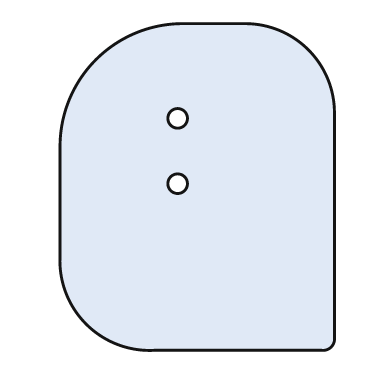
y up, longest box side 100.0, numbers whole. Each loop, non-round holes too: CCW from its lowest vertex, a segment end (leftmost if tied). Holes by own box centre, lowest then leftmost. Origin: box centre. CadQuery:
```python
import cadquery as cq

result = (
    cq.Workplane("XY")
    .moveTo(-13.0, -50.0)
    .lineTo(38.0, -50.0)
    .threePointArc((41.0, -49.0), (42.0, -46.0))
    .lineTo(42.0, 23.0)
    .threePointArc((34.0, 42.0), (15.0, 50.0))
    .lineTo(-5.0, 50.0)
    .threePointArc((-31.0, 39.0), (-42.0, 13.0))
    .lineTo(-42.0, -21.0)
    .threePointArc((-34.0, -42.0), (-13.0, -50.0))
    .close()
    .moveTo(-6.0, 1.0)
    .circle(3.0)
    .moveTo(-6.0, 21.0)
    .circle(3.0)
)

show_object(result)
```